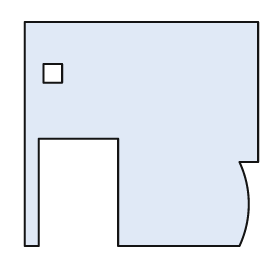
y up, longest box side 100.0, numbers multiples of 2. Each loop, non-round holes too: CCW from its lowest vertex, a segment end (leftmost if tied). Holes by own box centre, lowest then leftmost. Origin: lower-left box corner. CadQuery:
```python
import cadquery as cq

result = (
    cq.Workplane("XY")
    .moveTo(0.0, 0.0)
    .lineTo(6.0, 0.0)
    .lineTo(6.0, 46.0)
    .lineTo(40.0, 46.0)
    .lineTo(40.0, 0.0)
    .lineTo(92.0, 0.0)
    .threePointArc((96.0, 18.0), (92.0, 36.0))
    .lineTo(100.0, 36.0)
    .lineTo(100.0, 96.0)
    .lineTo(0.0, 96.0)
    .close()
    .moveTo(8.0, 70.0)
    .lineTo(16.0, 70.0)
    .lineTo(16.0, 78.0)
    .lineTo(8.0, 78.0)
    .close()
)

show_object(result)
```